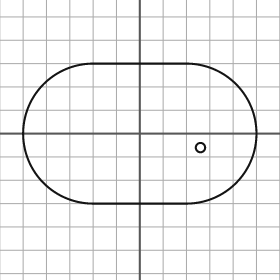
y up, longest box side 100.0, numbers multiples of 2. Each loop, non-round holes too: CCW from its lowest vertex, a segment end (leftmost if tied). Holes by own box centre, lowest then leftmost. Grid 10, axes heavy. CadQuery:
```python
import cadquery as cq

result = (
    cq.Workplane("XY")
    .moveTo(-20.0, -30.0)
    .lineTo(20.0, -30.0)
    .threePointArc((50.0, 0.0), (20.0, 30.0))
    .lineTo(-20.0, 30.0)
    .threePointArc((-50.0, 0.0), (-20.0, -30.0))
    .close()
    .moveTo(26.0, -6.0)
    .circle(2.0)
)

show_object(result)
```